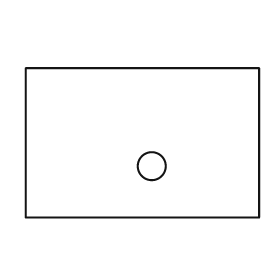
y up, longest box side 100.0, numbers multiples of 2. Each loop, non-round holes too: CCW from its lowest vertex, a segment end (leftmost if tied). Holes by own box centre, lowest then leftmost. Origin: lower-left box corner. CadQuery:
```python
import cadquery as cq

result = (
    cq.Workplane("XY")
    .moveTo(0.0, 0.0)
    .lineTo(100.0, 0.0)
    .lineTo(100.0, 64.0)
    .lineTo(0.0, 64.0)
    .close()
    .moveTo(54.0, 22.0)
    .circle(6.0)
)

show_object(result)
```